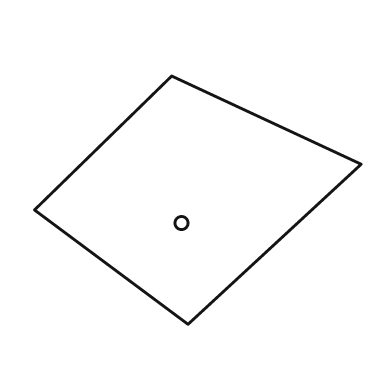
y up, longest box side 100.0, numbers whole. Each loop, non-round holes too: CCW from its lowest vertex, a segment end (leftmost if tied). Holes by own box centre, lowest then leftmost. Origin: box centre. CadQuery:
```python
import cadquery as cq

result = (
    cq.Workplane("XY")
    .moveTo(-3.0, -38.0)
    .lineTo(50.0, 11.0)
    .lineTo(-8.0, 38.0)
    .lineTo(-50.0, -3.0)
    .close()
    .moveTo(-5.0, -7.0)
    .circle(2.0)
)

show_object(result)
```